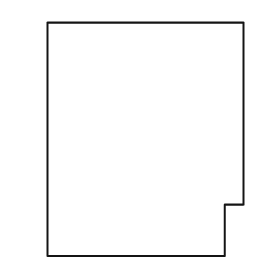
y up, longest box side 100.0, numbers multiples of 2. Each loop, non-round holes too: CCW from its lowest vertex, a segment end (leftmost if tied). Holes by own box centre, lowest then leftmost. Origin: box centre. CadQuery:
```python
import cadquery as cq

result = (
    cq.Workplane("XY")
    .moveTo(-42.0, -50.0)
    .lineTo(34.0, -50.0)
    .lineTo(34.0, -28.0)
    .lineTo(42.0, -28.0)
    .lineTo(42.0, 50.0)
    .lineTo(-42.0, 50.0)
    .close()
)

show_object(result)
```